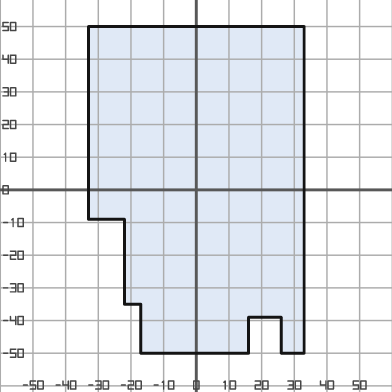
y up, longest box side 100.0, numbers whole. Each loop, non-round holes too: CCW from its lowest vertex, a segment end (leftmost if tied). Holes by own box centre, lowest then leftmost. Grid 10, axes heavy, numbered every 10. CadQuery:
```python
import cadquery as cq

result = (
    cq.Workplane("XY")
    .moveTo(-17.0, -50.0)
    .lineTo(16.0, -50.0)
    .lineTo(16.0, -39.0)
    .lineTo(26.0, -39.0)
    .lineTo(26.0, -50.0)
    .lineTo(33.0, -50.0)
    .lineTo(33.0, 50.0)
    .lineTo(-33.0, 50.0)
    .lineTo(-33.0, -9.0)
    .lineTo(-22.0, -9.0)
    .lineTo(-22.0, -35.0)
    .lineTo(-17.0, -35.0)
    .close()
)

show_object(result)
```